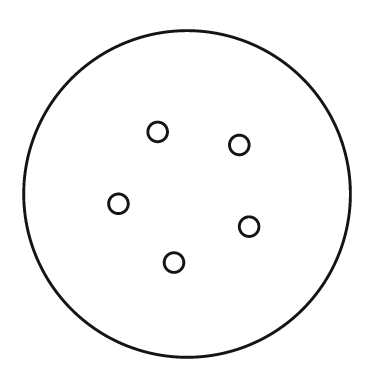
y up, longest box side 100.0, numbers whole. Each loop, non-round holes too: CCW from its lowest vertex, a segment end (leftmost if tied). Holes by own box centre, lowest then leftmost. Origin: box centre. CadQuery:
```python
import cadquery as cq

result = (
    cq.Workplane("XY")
    .moveTo(0.0, 0.0)
    .circle(50.0)
    .moveTo(-4.0, -21.0)
    .circle(3.0)
    .moveTo(19.0, -10.0)
    .circle(3.0)
    .moveTo(-21.0, -3.0)
    .circle(3.0)
    .moveTo(16.0, 15.0)
    .circle(3.0)
    .moveTo(-9.0, 19.0)
    .circle(3.0)
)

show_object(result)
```